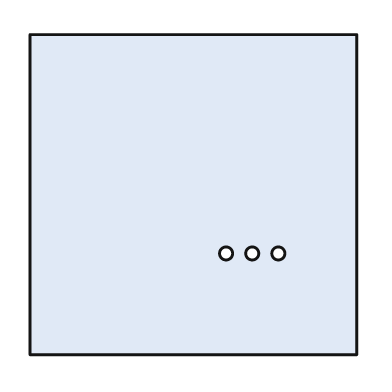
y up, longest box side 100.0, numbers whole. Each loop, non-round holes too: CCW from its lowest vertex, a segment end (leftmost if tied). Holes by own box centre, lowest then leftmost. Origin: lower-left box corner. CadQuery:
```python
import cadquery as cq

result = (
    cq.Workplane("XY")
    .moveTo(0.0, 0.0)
    .lineTo(100.0, 0.0)
    .lineTo(100.0, 98.0)
    .lineTo(0.0, 98.0)
    .close()
    .moveTo(60.0, 31.0)
    .circle(2.0)
    .moveTo(68.0, 31.0)
    .circle(2.0)
    .moveTo(76.0, 31.0)
    .circle(2.0)
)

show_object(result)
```